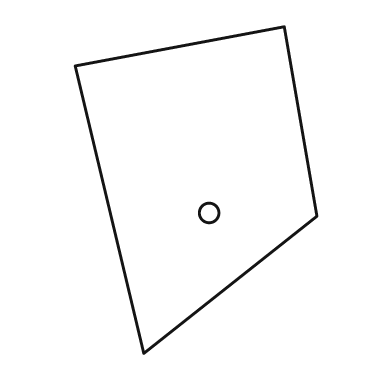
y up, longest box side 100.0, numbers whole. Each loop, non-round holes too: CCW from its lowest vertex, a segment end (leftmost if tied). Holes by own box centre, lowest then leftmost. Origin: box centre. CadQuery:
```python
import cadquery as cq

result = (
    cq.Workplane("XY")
    .moveTo(-16.0, -50.0)
    .lineTo(37.0, -8.0)
    .lineTo(27.0, 50.0)
    .lineTo(-37.0, 38.0)
    .close()
    .moveTo(4.0, -7.0)
    .circle(3.0)
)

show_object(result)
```